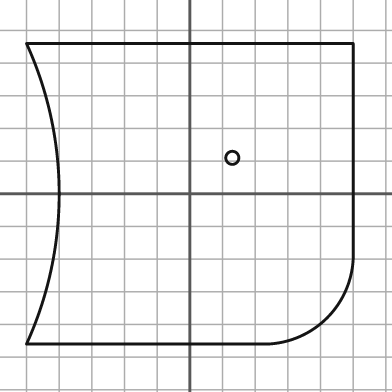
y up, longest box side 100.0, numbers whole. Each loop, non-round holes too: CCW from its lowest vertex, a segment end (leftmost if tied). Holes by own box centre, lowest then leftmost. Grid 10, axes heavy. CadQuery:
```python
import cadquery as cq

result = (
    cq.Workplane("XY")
    .moveTo(-50.0, -46.0)
    .lineTo(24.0, -46.0)
    .threePointArc((42.0, -38.0), (50.0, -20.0))
    .lineTo(50.0, 46.0)
    .lineTo(-50.0, 46.0)
    .threePointArc((-40.0, 0.0), (-50.0, -46.0))
    .close()
    .moveTo(13.0, 11.0)
    .circle(2.0)
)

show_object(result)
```